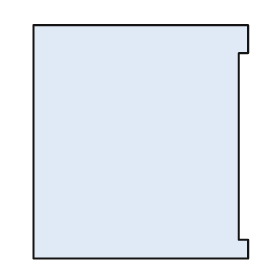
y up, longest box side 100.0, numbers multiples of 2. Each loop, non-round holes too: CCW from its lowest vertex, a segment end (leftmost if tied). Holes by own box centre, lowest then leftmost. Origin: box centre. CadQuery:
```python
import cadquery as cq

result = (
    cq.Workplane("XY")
    .moveTo(-46.0, -50.0)
    .lineTo(46.0, -50.0)
    .lineTo(46.0, -42.0)
    .lineTo(42.0, -42.0)
    .lineTo(42.0, 38.0)
    .lineTo(46.0, 38.0)
    .lineTo(46.0, 50.0)
    .lineTo(-46.0, 50.0)
    .close()
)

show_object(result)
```